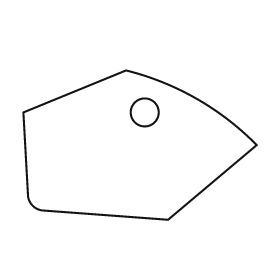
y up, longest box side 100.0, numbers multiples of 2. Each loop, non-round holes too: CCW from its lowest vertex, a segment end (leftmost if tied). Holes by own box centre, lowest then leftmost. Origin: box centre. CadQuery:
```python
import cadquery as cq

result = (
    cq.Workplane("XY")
    .moveTo(12.0, -32.0)
    .lineTo(50.0, 0.0)
    .threePointArc((24.0, 20.0), (-6.0, 32.0))
    .lineTo(-50.0, 14.0)
    .lineTo(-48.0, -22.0)
    .threePointArc((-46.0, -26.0), (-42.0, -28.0))
    .close()
    .moveTo(2.0, 14.0)
    .circle(6.0)
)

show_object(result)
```